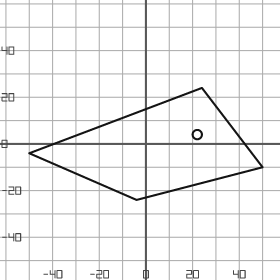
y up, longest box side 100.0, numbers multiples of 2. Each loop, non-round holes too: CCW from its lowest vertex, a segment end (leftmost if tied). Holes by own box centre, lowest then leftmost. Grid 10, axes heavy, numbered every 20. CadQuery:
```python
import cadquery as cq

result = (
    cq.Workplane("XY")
    .moveTo(-4.0, -24.0)
    .lineTo(50.0, -10.0)
    .lineTo(24.0, 24.0)
    .lineTo(-50.0, -4.0)
    .close()
    .moveTo(22.0, 4.0)
    .circle(2.0)
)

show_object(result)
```